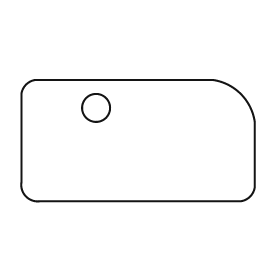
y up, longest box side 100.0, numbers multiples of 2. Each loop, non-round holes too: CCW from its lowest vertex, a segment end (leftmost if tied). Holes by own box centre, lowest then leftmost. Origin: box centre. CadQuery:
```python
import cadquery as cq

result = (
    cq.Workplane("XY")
    .moveTo(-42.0, -26.0)
    .lineTo(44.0, -26.0)
    .threePointArc((48.0, -24.0), (50.0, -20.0))
    .lineTo(50.0, 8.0)
    .threePointArc((44.0, 20.0), (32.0, 26.0))
    .lineTo(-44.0, 26.0)
    .threePointArc((-48.0, 24.0), (-50.0, 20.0))
    .lineTo(-50.0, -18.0)
    .threePointArc((-48.0, -24.0), (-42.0, -26.0))
    .close()
    .moveTo(-18.0, 14.0)
    .circle(6.0)
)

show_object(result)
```